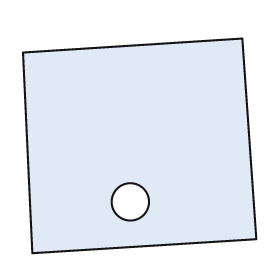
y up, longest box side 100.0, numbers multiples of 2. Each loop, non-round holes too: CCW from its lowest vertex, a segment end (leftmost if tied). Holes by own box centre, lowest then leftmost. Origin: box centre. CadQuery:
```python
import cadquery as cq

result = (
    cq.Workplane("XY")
    .moveTo(-46.0, -46.0)
    .lineTo(50.0, -40.0)
    .lineTo(44.0, 46.0)
    .lineTo(-50.0, 40.0)
    .close()
    .moveTo(-4.0, -24.0)
    .circle(8.0)
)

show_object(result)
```